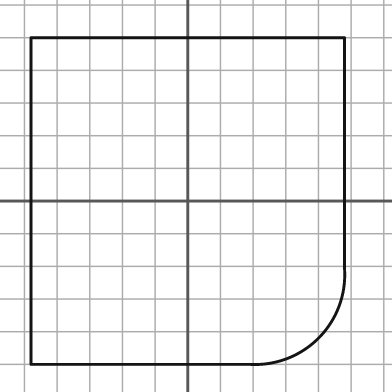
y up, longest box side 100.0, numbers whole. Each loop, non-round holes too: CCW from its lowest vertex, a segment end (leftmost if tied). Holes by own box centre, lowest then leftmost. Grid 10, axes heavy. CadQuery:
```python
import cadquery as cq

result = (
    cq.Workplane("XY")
    .moveTo(-48.0, -50.0)
    .lineTo(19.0, -50.0)
    .threePointArc((40.0, -42.0), (48.0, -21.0))
    .lineTo(48.0, 50.0)
    .lineTo(-48.0, 50.0)
    .close()
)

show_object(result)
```